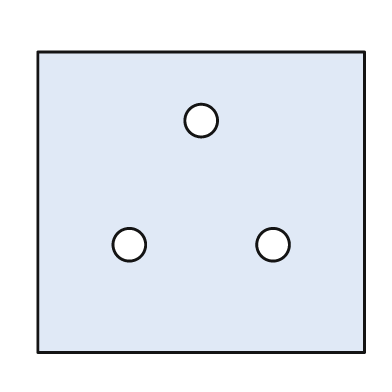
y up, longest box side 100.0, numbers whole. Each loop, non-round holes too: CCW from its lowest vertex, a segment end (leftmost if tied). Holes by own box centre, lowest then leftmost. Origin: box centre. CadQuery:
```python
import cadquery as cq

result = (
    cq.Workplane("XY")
    .moveTo(-50.0, -46.0)
    .lineTo(50.0, -46.0)
    .lineTo(50.0, 46.0)
    .lineTo(-50.0, 46.0)
    .close()
    .moveTo(-22.0, -13.0)
    .circle(5.0)
    .moveTo(22.0, -13.0)
    .circle(5.0)
    .moveTo(0.0, 25.0)
    .circle(5.0)
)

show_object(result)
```